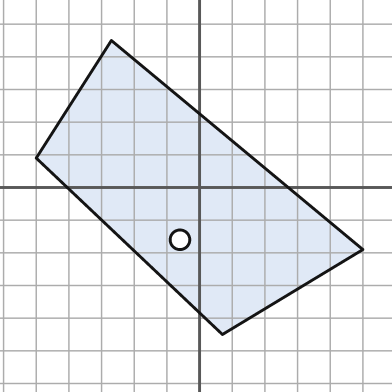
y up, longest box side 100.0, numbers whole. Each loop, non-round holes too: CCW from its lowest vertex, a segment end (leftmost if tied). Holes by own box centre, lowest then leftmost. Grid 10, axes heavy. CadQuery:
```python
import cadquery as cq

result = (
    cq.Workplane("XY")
    .moveTo(7.0, -45.0)
    .lineTo(50.0, -19.0)
    .lineTo(-27.0, 45.0)
    .lineTo(-50.0, 9.0)
    .close()
    .moveTo(-6.0, -16.0)
    .circle(3.0)
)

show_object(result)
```